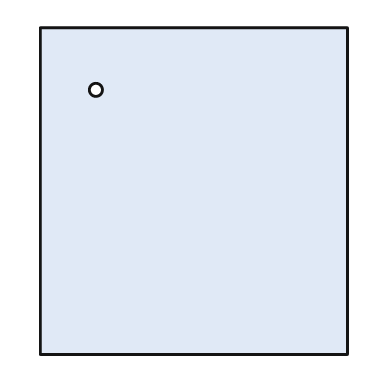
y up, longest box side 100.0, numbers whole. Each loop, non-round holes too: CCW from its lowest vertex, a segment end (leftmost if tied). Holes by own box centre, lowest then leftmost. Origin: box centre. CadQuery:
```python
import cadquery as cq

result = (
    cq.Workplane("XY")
    .moveTo(-47.0, -50.0)
    .lineTo(47.0, -50.0)
    .lineTo(47.0, 50.0)
    .lineTo(-47.0, 50.0)
    .close()
    .moveTo(-30.0, 31.0)
    .circle(2.0)
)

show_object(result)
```